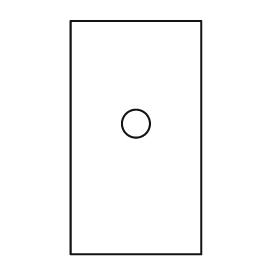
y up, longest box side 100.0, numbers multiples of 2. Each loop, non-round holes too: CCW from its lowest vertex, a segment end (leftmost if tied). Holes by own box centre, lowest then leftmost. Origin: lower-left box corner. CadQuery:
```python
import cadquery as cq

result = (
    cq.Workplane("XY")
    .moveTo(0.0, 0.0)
    .lineTo(56.0, 0.0)
    .lineTo(56.0, 100.0)
    .lineTo(0.0, 100.0)
    .close()
    .moveTo(28.0, 56.0)
    .circle(6.0)
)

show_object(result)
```